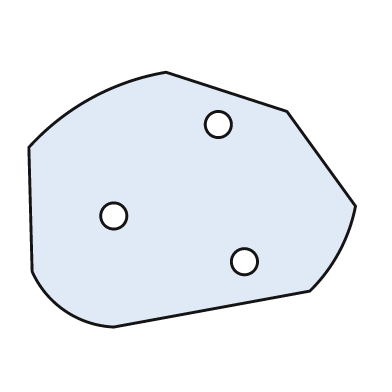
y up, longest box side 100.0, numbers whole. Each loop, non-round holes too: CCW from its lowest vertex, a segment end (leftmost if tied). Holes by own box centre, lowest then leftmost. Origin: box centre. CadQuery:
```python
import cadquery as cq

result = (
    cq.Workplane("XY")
    .moveTo(-24.0, -39.0)
    .lineTo(36.0, -28.0)
    .threePointArc((45.0, -16.0), (50.0, -2.0))
    .lineTo(29.0, 27.0)
    .lineTo(-8.0, 39.0)
    .threePointArc((-31.0, 31.0), (-50.0, 16.0))
    .lineTo(-49.0, -22.0)
    .threePointArc((-39.0, -34.0), (-24.0, -39.0))
    .close()
    .moveTo(16.0, -19.0)
    .circle(4.0)
    .moveTo(-24.0, -5.0)
    .circle(4.0)
    .moveTo(8.0, 23.0)
    .circle(4.0)
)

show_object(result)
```